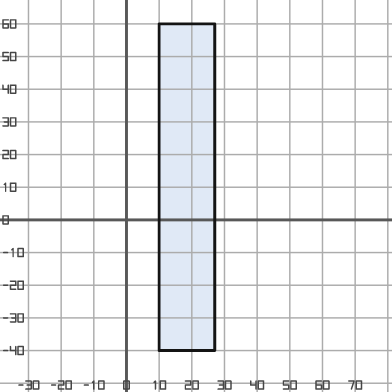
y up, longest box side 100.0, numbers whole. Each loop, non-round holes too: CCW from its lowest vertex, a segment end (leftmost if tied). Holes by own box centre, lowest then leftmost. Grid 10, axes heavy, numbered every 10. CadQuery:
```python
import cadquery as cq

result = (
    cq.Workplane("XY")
    .moveTo(10.0, -40.0)
    .lineTo(27.0, -40.0)
    .lineTo(27.0, 60.0)
    .lineTo(10.0, 60.0)
    .close()
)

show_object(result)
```